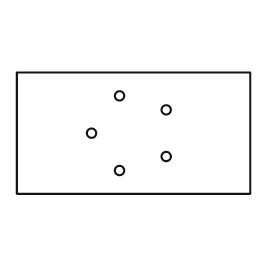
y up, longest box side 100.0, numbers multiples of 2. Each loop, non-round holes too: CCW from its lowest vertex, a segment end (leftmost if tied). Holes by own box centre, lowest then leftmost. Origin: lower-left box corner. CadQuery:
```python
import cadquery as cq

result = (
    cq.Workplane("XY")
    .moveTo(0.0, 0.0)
    .lineTo(100.0, 0.0)
    .lineTo(100.0, 52.0)
    .lineTo(0.0, 52.0)
    .close()
    .moveTo(44.0, 10.0)
    .circle(2.0)
    .moveTo(64.0, 16.0)
    .circle(2.0)
    .moveTo(32.0, 26.0)
    .circle(2.0)
    .moveTo(64.0, 36.0)
    .circle(2.0)
    .moveTo(44.0, 42.0)
    .circle(2.0)
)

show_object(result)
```